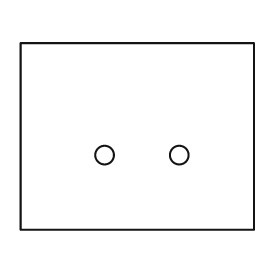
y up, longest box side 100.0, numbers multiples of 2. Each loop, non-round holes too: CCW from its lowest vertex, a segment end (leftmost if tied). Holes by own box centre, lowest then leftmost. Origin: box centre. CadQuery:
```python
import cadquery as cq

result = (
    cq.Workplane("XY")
    .moveTo(-50.0, -40.0)
    .lineTo(50.0, -40.0)
    .lineTo(50.0, 40.0)
    .lineTo(-50.0, 40.0)
    .close()
    .moveTo(-14.0, -8.0)
    .circle(4.0)
    .moveTo(18.0, -8.0)
    .circle(4.0)
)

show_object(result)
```